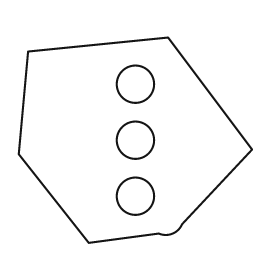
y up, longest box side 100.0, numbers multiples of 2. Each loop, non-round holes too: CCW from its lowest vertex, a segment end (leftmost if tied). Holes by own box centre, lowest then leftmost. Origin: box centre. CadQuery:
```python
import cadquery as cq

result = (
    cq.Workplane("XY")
    .moveTo(-20.0, -44.0)
    .lineTo(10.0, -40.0)
    .threePointArc((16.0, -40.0), (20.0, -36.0))
    .lineTo(50.0, -4.0)
    .lineTo(14.0, 44.0)
    .lineTo(-46.0, 38.0)
    .lineTo(-50.0, -6.0)
    .close()
    .moveTo(0.0, -24.0)
    .circle(8.0)
    .moveTo(0.0, 0.0)
    .circle(8.0)
    .moveTo(0.0, 24.0)
    .circle(8.0)
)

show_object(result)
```